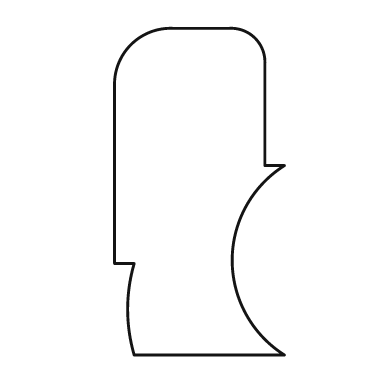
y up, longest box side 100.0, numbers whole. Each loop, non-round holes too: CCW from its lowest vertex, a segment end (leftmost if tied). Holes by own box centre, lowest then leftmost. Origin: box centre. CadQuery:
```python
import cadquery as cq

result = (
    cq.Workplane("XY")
    .moveTo(-20.0, -50.0)
    .lineTo(26.0, -50.0)
    .threePointArc((10.0, -21.0), (26.0, 8.0))
    .lineTo(20.0, 8.0)
    .lineTo(20.0, 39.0)
    .threePointArc((17.0, 47.0), (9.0, 50.0))
    .lineTo(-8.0, 50.0)
    .threePointArc((-21.0, 45.0), (-26.0, 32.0))
    .lineTo(-26.0, -22.0)
    .lineTo(-20.0, -22.0)
    .threePointArc((-22.0, -36.0), (-20.0, -50.0))
    .close()
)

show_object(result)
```